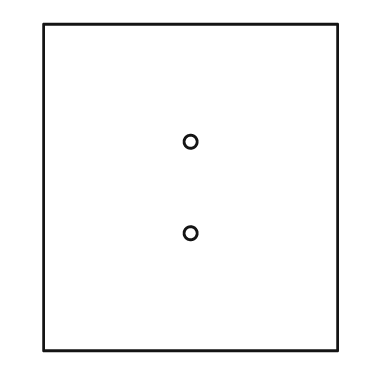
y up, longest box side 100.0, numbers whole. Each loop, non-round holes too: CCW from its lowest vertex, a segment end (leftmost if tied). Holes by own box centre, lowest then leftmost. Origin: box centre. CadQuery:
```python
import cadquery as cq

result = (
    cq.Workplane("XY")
    .moveTo(-45.0, -50.0)
    .lineTo(45.0, -50.0)
    .lineTo(45.0, 50.0)
    .lineTo(-45.0, 50.0)
    .close()
    .moveTo(0.0, -14.0)
    .circle(2.0)
    .moveTo(0.0, 14.0)
    .circle(2.0)
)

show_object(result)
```